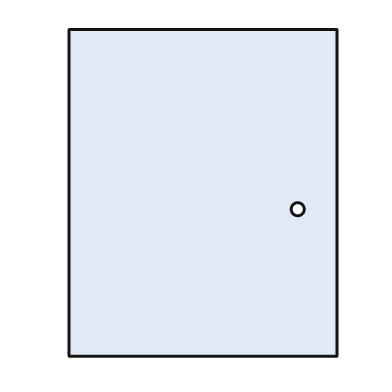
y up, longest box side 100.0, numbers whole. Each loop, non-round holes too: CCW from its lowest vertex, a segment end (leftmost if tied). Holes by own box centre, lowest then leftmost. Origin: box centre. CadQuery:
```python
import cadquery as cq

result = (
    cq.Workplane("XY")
    .moveTo(-41.0, -50.0)
    .lineTo(41.0, -50.0)
    .lineTo(41.0, 50.0)
    .lineTo(-41.0, 50.0)
    .close()
    .moveTo(29.0, -5.0)
    .circle(2.0)
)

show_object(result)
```